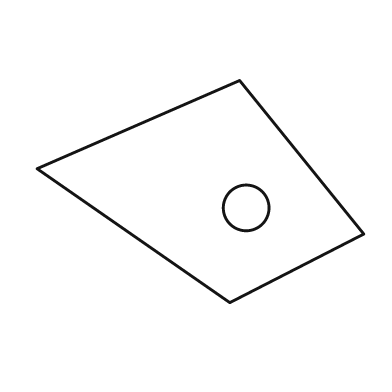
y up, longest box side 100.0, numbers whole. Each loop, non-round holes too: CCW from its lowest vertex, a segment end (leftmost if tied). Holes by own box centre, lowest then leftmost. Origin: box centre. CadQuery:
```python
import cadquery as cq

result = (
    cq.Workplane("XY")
    .moveTo(9.0, -34.0)
    .lineTo(50.0, -13.0)
    .lineTo(12.0, 34.0)
    .lineTo(-50.0, 7.0)
    .close()
    .moveTo(14.0, -5.0)
    .circle(7.0)
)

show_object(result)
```